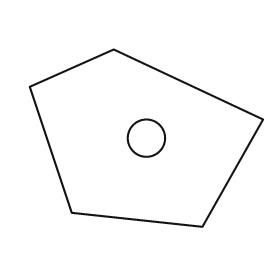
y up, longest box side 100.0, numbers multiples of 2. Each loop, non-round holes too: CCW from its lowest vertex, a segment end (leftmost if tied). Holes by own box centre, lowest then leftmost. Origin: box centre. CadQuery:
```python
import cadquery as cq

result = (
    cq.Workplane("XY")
    .moveTo(24.0, -38.0)
    .lineTo(50.0, 8.0)
    .lineTo(-14.0, 38.0)
    .lineTo(-50.0, 22.0)
    .lineTo(-32.0, -32.0)
    .close()
    .moveTo(0.0, 0.0)
    .circle(8.0)
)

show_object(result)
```